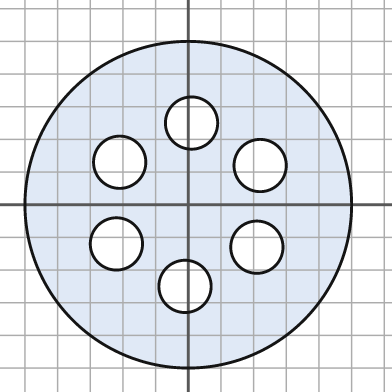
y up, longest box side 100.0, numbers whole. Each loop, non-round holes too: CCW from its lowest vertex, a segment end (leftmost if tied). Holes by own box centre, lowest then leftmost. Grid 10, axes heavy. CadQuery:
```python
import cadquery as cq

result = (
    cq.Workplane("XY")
    .moveTo(0.0, 0.0)
    .circle(50.0)
    .moveTo(-1.0, -25.0)
    .circle(8.0)
    .moveTo(21.0, -13.0)
    .circle(8.0)
    .moveTo(-22.0, -12.0)
    .circle(8.0)
    .moveTo(22.0, 12.0)
    .circle(8.0)
    .moveTo(-21.0, 13.0)
    .circle(8.0)
    .moveTo(1.0, 25.0)
    .circle(8.0)
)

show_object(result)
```